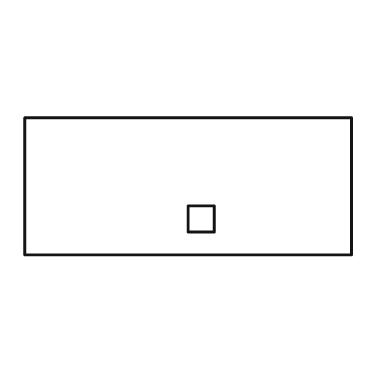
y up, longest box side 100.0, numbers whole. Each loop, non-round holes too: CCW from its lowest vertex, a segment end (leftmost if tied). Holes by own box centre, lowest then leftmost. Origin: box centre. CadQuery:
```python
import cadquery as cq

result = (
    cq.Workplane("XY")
    .moveTo(-50.0, -21.0)
    .lineTo(50.0, -21.0)
    .lineTo(50.0, 21.0)
    .lineTo(-50.0, 21.0)
    .close()
    .moveTo(0.0, -14.0)
    .lineTo(8.0, -14.0)
    .lineTo(8.0, -6.0)
    .lineTo(0.0, -6.0)
    .close()
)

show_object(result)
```